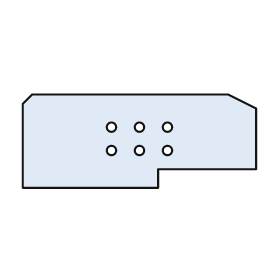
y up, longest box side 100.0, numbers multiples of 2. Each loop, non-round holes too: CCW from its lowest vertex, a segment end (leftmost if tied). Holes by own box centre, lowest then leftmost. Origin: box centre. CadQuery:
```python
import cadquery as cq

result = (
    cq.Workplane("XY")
    .moveTo(-50.0, -20.0)
    .lineTo(8.0, -20.0)
    .lineTo(8.0, -12.0)
    .lineTo(50.0, -12.0)
    .lineTo(50.0, 14.0)
    .lineTo(38.0, 20.0)
    .lineTo(-46.0, 20.0)
    .lineTo(-50.0, 16.0)
    .close()
    .moveTo(-12.0, -4.0)
    .circle(2.0)
    .moveTo(0.0, -4.0)
    .circle(2.0)
    .moveTo(12.0, -4.0)
    .circle(2.0)
    .moveTo(-12.0, 6.0)
    .circle(2.0)
    .moveTo(0.0, 6.0)
    .circle(2.0)
    .moveTo(12.0, 6.0)
    .circle(2.0)
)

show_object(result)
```